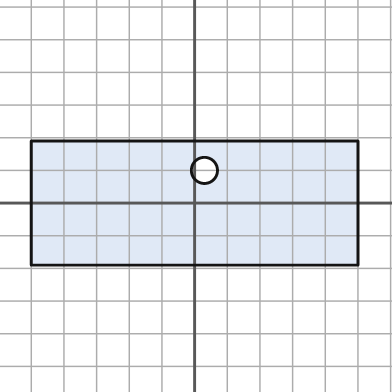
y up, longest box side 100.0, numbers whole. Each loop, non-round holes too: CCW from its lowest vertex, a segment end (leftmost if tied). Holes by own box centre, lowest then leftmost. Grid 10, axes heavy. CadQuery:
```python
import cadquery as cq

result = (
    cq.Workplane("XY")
    .moveTo(-50.0, -19.0)
    .lineTo(50.0, -19.0)
    .lineTo(50.0, 19.0)
    .lineTo(-50.0, 19.0)
    .close()
    .moveTo(3.0, 10.0)
    .circle(4.0)
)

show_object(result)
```